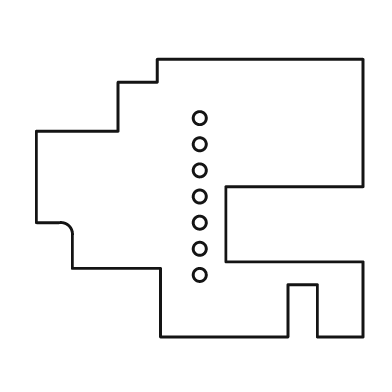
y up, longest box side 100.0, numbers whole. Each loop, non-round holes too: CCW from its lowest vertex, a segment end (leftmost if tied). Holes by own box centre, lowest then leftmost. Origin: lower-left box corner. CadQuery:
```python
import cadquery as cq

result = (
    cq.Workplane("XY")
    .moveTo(38.0, 0.0)
    .lineTo(77.0, 0.0)
    .lineTo(77.0, 16.0)
    .lineTo(86.0, 16.0)
    .lineTo(86.0, 0.0)
    .lineTo(100.0, 0.0)
    .lineTo(100.0, 23.0)
    .lineTo(58.0, 23.0)
    .lineTo(58.0, 46.0)
    .lineTo(100.0, 46.0)
    .lineTo(100.0, 85.0)
    .lineTo(37.0, 85.0)
    .lineTo(37.0, 78.0)
    .lineTo(25.0, 78.0)
    .lineTo(25.0, 63.0)
    .lineTo(0.0, 63.0)
    .lineTo(0.0, 35.0)
    .lineTo(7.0, 35.0)
    .threePointArc((10.0, 34.0), (11.0, 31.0))
    .lineTo(11.0, 21.0)
    .lineTo(38.0, 21.0)
    .close()
    .moveTo(50.0, 19.0)
    .circle(2.0)
    .moveTo(50.0, 27.0)
    .circle(2.0)
    .moveTo(50.0, 35.0)
    .circle(2.0)
    .moveTo(50.0, 43.0)
    .circle(2.0)
    .moveTo(50.0, 51.0)
    .circle(2.0)
    .moveTo(50.0, 59.0)
    .circle(2.0)
    .moveTo(50.0, 67.0)
    .circle(2.0)
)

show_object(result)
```